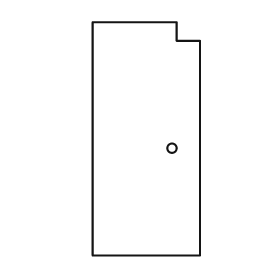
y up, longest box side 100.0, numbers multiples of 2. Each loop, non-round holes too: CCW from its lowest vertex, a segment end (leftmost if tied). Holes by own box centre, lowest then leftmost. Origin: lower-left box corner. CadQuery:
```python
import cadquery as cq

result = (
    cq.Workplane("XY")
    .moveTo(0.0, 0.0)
    .lineTo(46.0, 0.0)
    .lineTo(46.0, 92.0)
    .lineTo(36.0, 92.0)
    .lineTo(36.0, 100.0)
    .lineTo(0.0, 100.0)
    .close()
    .moveTo(34.0, 46.0)
    .circle(2.0)
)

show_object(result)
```